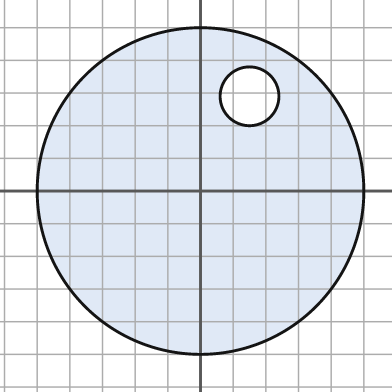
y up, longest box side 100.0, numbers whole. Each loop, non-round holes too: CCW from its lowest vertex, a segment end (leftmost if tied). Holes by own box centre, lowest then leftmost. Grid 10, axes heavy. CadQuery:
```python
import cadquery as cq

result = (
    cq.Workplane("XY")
    .moveTo(0.0, 0.0)
    .circle(50.0)
    .moveTo(15.0, 29.0)
    .circle(9.0)
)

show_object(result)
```